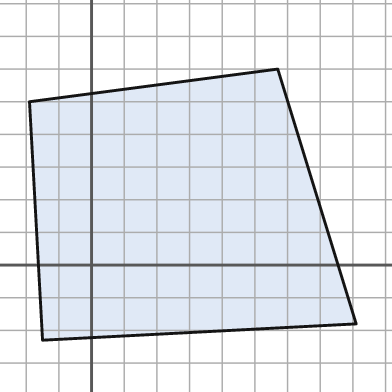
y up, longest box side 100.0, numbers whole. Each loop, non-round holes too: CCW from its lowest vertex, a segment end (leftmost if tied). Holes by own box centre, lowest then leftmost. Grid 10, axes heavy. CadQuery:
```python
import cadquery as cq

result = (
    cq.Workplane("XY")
    .moveTo(-15.0, -23.0)
    .lineTo(81.0, -18.0)
    .lineTo(57.0, 60.0)
    .lineTo(-19.0, 50.0)
    .close()
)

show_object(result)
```